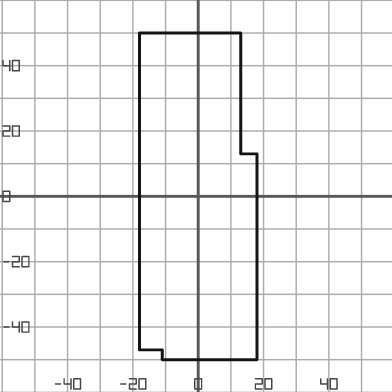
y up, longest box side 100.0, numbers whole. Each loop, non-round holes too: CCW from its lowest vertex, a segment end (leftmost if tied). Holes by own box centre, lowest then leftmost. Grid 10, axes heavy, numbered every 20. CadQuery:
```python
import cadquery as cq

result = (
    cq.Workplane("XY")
    .moveTo(-11.0, -50.0)
    .lineTo(18.0, -50.0)
    .lineTo(18.0, 13.0)
    .lineTo(13.0, 13.0)
    .lineTo(13.0, 50.0)
    .lineTo(-18.0, 50.0)
    .lineTo(-18.0, -47.0)
    .lineTo(-11.0, -47.0)
    .close()
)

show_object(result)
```